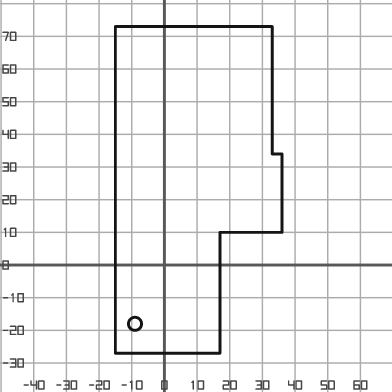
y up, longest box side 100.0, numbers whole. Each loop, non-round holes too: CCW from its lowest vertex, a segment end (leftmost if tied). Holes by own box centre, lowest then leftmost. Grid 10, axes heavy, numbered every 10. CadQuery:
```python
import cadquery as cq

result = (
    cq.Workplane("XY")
    .moveTo(-15.0, -27.0)
    .lineTo(17.0, -27.0)
    .lineTo(17.0, 10.0)
    .lineTo(36.0, 10.0)
    .lineTo(36.0, 34.0)
    .lineTo(33.0, 34.0)
    .lineTo(33.0, 73.0)
    .lineTo(-15.0, 73.0)
    .close()
    .moveTo(-9.0, -18.0)
    .circle(2.0)
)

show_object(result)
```